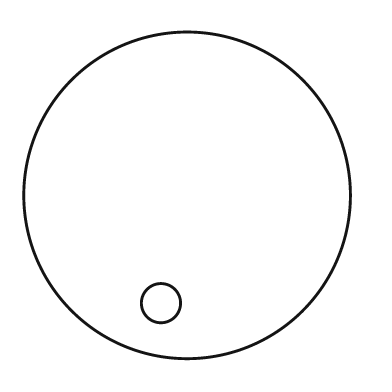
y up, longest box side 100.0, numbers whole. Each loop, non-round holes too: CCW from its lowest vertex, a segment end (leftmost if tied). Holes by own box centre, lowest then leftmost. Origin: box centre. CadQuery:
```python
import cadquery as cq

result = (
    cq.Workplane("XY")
    .moveTo(0.0, 0.0)
    .circle(50.0)
    .moveTo(-8.0, -33.0)
    .circle(6.0)
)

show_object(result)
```